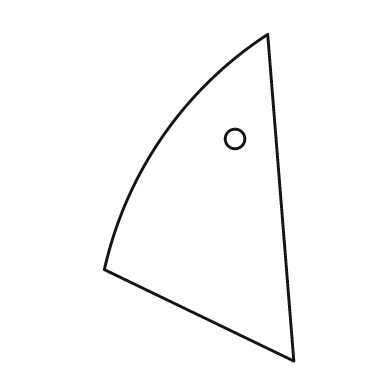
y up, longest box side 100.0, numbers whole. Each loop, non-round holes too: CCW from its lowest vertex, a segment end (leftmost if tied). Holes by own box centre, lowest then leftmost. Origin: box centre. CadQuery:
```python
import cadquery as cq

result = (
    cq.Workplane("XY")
    .moveTo(29.0, -50.0)
    .lineTo(21.0, 50.0)
    .threePointArc((-11.0, 19.0), (-29.0, -22.0))
    .close()
    .moveTo(11.0, 18.0)
    .circle(3.0)
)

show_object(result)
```